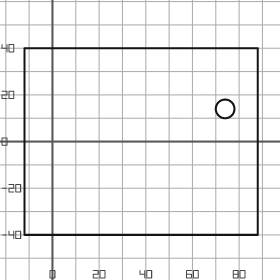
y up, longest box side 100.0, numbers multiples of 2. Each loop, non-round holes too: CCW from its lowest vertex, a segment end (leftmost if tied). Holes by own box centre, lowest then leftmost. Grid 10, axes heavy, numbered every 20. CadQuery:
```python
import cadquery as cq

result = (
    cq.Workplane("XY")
    .moveTo(-12.0, -40.0)
    .lineTo(88.0, -40.0)
    .lineTo(88.0, 40.0)
    .lineTo(-12.0, 40.0)
    .close()
    .moveTo(74.0, 14.0)
    .circle(4.0)
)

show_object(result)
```